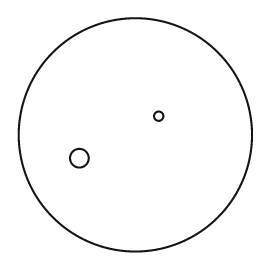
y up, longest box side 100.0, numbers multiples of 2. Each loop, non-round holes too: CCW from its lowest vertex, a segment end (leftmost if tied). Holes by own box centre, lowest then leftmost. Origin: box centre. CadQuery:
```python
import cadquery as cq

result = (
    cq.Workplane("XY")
    .moveTo(0.0, 0.0)
    .circle(50.0)
    .moveTo(-24.0, -10.0)
    .circle(4.0)
    .moveTo(10.0, 8.0)
    .circle(2.0)
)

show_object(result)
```